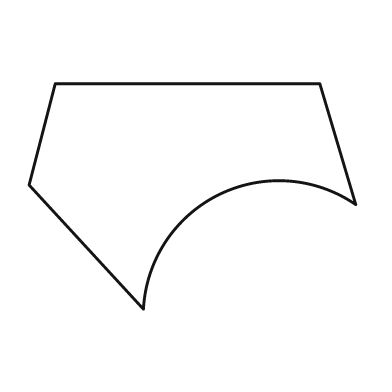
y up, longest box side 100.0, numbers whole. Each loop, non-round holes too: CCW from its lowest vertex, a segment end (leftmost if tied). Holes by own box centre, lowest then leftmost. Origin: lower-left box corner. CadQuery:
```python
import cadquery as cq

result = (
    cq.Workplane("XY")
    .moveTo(35.0, 0.0)
    .threePointArc((58.0, 35.0), (100.0, 32.0))
    .lineTo(89.0, 69.0)
    .lineTo(8.0, 69.0)
    .lineTo(0.0, 38.0)
    .close()
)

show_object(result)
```